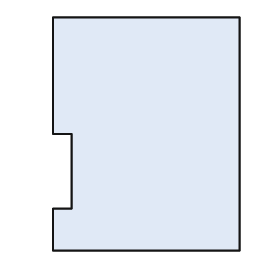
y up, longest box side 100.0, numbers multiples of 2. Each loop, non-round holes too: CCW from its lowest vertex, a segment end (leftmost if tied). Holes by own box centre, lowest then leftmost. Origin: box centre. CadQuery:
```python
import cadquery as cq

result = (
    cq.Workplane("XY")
    .moveTo(-40.0, -50.0)
    .lineTo(40.0, -50.0)
    .lineTo(40.0, 50.0)
    .lineTo(-40.0, 50.0)
    .lineTo(-40.0, 0.0)
    .lineTo(-32.0, 0.0)
    .lineTo(-32.0, -32.0)
    .lineTo(-40.0, -32.0)
    .close()
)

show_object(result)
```